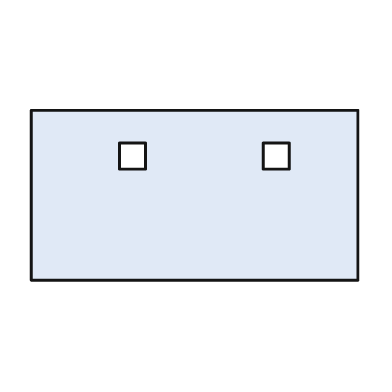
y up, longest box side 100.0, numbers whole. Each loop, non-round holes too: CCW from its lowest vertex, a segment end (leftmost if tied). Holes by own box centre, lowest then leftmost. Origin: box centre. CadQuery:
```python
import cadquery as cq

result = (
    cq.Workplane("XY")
    .moveTo(-50.0, -26.0)
    .lineTo(50.0, -26.0)
    .lineTo(50.0, 26.0)
    .lineTo(-50.0, 26.0)
    .close()
    .moveTo(-23.0, 8.0)
    .lineTo(-15.0, 8.0)
    .lineTo(-15.0, 16.0)
    .lineTo(-23.0, 16.0)
    .close()
    .moveTo(21.0, 8.0)
    .lineTo(29.0, 8.0)
    .lineTo(29.0, 16.0)
    .lineTo(21.0, 16.0)
    .close()
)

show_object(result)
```